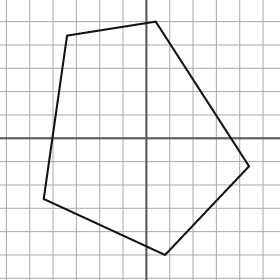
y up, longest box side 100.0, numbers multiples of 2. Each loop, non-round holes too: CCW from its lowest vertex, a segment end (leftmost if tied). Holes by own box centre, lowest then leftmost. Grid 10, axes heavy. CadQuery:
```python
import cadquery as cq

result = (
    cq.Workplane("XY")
    .moveTo(8.0, -50.0)
    .lineTo(44.0, -12.0)
    .lineTo(4.0, 50.0)
    .lineTo(-34.0, 44.0)
    .lineTo(-44.0, -26.0)
    .close()
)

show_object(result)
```